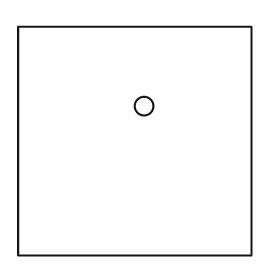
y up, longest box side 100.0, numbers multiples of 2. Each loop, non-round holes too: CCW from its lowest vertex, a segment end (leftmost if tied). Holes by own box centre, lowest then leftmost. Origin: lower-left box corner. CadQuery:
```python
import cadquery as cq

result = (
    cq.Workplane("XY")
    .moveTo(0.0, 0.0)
    .lineTo(100.0, 0.0)
    .lineTo(100.0, 98.0)
    .lineTo(0.0, 98.0)
    .close()
    .moveTo(54.0, 64.0)
    .circle(4.0)
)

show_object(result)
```